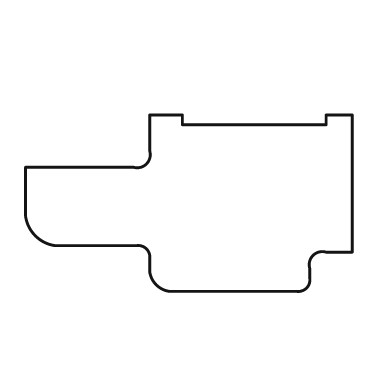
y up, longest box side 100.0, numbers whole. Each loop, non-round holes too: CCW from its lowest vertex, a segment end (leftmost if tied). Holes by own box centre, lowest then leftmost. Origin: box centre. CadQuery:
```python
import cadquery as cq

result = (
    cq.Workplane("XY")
    .moveTo(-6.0, -27.0)
    .lineTo(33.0, -27.0)
    .threePointArc((36.0, -26.0), (37.0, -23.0))
    .lineTo(37.0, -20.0)
    .threePointArc((38.0, -16.0), (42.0, -15.0))
    .lineTo(50.0, -15.0)
    .lineTo(50.0, 27.0)
    .lineTo(42.0, 27.0)
    .lineTo(42.0, 24.0)
    .lineTo(-2.0, 24.0)
    .lineTo(-2.0, 27.0)
    .lineTo(-12.0, 27.0)
    .lineTo(-12.0, 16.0)
    .threePointArc((-13.0, 12.0), (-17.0, 11.0))
    .lineTo(-50.0, 11.0)
    .lineTo(-50.0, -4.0)
    .threePointArc((-47.0, -10.0), (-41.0, -13.0))
    .lineTo(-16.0, -13.0)
    .threePointArc((-13.0, -14.0), (-12.0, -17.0))
    .lineTo(-12.0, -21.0)
    .threePointArc((-10.0, -25.0), (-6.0, -27.0))
    .close()
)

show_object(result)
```